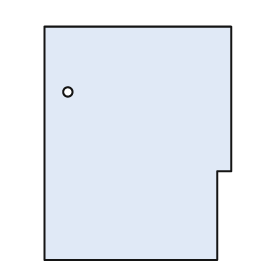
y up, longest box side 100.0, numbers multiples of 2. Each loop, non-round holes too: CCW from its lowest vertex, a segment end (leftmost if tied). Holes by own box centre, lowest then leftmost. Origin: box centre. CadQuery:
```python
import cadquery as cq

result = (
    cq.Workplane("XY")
    .moveTo(-40.0, -50.0)
    .lineTo(34.0, -50.0)
    .lineTo(34.0, -12.0)
    .lineTo(40.0, -12.0)
    .lineTo(40.0, 50.0)
    .lineTo(-40.0, 50.0)
    .close()
    .moveTo(-30.0, 22.0)
    .circle(2.0)
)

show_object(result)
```